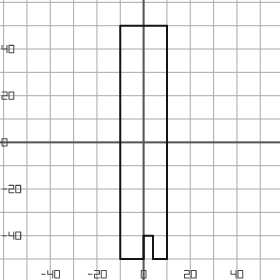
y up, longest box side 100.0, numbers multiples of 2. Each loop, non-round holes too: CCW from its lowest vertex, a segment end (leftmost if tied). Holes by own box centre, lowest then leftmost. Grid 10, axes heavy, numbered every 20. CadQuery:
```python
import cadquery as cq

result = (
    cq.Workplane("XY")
    .moveTo(-10.0, -50.0)
    .lineTo(0.0, -50.0)
    .lineTo(0.0, -40.0)
    .lineTo(4.0, -40.0)
    .lineTo(4.0, -50.0)
    .lineTo(10.0, -50.0)
    .lineTo(10.0, 50.0)
    .lineTo(-10.0, 50.0)
    .close()
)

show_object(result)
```